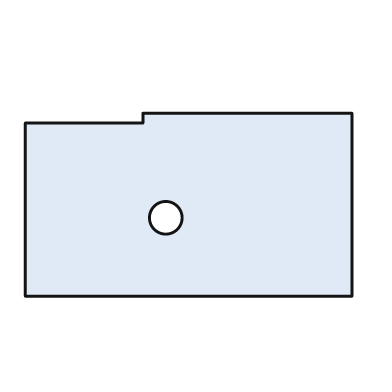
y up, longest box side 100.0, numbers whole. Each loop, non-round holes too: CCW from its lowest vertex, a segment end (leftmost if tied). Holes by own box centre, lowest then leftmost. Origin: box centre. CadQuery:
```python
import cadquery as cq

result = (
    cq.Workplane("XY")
    .moveTo(-50.0, -28.0)
    .lineTo(50.0, -28.0)
    .lineTo(50.0, 28.0)
    .lineTo(-14.0, 28.0)
    .lineTo(-14.0, 25.0)
    .lineTo(-50.0, 25.0)
    .close()
    .moveTo(-7.0, -4.0)
    .circle(5.0)
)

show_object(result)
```